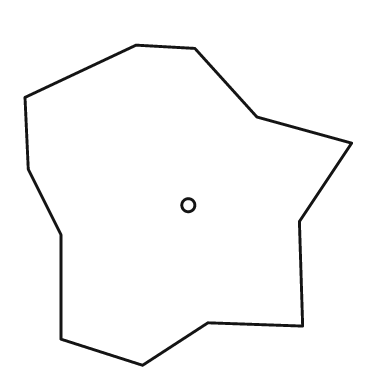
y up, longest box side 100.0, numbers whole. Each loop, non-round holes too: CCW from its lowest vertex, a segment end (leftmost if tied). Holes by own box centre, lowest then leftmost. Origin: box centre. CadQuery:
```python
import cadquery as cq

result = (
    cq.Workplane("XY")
    .moveTo(-14.0, -49.0)
    .lineTo(6.0, -36.0)
    .lineTo(35.0, -37.0)
    .lineTo(34.0, -5.0)
    .lineTo(50.0, 19.0)
    .lineTo(21.0, 27.0)
    .lineTo(2.0, 48.0)
    .lineTo(-16.0, 49.0)
    .lineTo(-50.0, 33.0)
    .lineTo(-49.0, 11.0)
    .lineTo(-39.0, -9.0)
    .lineTo(-39.0, -41.0)
    .close()
    .moveTo(0.0, 0.0)
    .circle(2.0)
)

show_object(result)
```